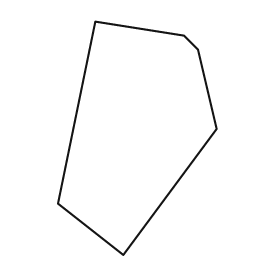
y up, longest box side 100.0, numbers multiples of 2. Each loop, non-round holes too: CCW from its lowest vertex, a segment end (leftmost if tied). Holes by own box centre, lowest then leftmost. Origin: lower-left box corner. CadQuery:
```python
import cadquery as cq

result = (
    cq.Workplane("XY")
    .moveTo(28.0, 0.0)
    .lineTo(68.0, 54.0)
    .lineTo(60.0, 88.0)
    .lineTo(54.0, 94.0)
    .lineTo(16.0, 100.0)
    .lineTo(0.0, 22.0)
    .close()
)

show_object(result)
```